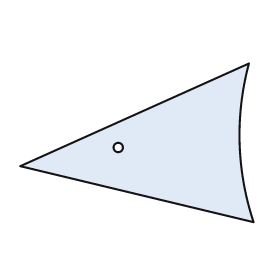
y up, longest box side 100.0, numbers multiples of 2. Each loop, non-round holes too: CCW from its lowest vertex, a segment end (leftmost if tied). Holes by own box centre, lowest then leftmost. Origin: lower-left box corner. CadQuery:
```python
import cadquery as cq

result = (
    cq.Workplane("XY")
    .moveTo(100.0, 0.0)
    .threePointArc((94.0, 34.0), (98.0, 68.0))
    .lineTo(0.0, 24.0)
    .close()
    .moveTo(42.0, 32.0)
    .circle(2.0)
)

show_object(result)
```